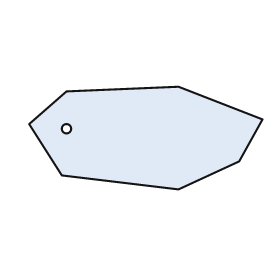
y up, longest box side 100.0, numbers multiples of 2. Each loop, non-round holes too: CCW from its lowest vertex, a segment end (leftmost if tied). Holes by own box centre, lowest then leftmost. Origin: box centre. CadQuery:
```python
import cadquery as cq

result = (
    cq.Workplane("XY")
    .moveTo(14.0, -22.0)
    .lineTo(40.0, -10.0)
    .lineTo(50.0, 8.0)
    .lineTo(14.0, 22.0)
    .lineTo(-34.0, 20.0)
    .lineTo(-50.0, 6.0)
    .lineTo(-36.0, -16.0)
    .close()
    .moveTo(-34.0, 4.0)
    .circle(2.0)
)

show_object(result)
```